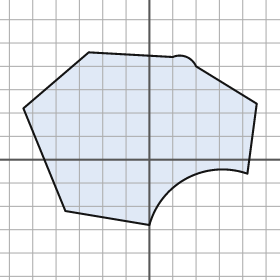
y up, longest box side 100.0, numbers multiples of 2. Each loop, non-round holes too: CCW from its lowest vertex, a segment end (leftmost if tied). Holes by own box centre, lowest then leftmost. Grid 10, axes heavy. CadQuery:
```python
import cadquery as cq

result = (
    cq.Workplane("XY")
    .moveTo(0.0, -28.0)
    .threePointArc((16.0, -8.0), (42.0, -6.0))
    .lineTo(46.0, 24.0)
    .lineTo(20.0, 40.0)
    .threePointArc((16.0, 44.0), (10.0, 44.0))
    .lineTo(-26.0, 46.0)
    .lineTo(-54.0, 22.0)
    .lineTo(-36.0, -22.0)
    .close()
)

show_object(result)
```